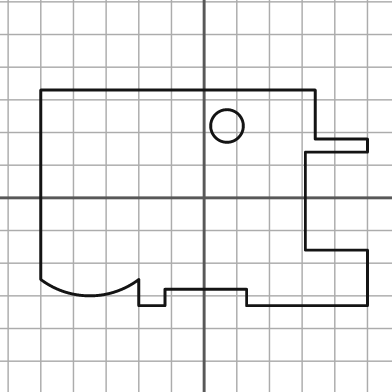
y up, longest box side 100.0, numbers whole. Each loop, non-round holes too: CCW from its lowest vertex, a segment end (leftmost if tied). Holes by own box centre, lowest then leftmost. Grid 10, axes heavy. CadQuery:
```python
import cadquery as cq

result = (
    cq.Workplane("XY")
    .moveTo(-20.0, -33.0)
    .lineTo(-12.0, -33.0)
    .lineTo(-12.0, -28.0)
    .lineTo(13.0, -28.0)
    .lineTo(13.0, -33.0)
    .lineTo(50.0, -33.0)
    .lineTo(50.0, -16.0)
    .lineTo(31.0, -16.0)
    .lineTo(31.0, 14.0)
    .lineTo(50.0, 14.0)
    .lineTo(50.0, 18.0)
    .lineTo(34.0, 18.0)
    .lineTo(34.0, 33.0)
    .lineTo(-50.0, 33.0)
    .lineTo(-50.0, -25.0)
    .threePointArc((-35.0, -30.0), (-20.0, -25.0))
    .close()
    .moveTo(7.0, 22.0)
    .circle(5.0)
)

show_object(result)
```